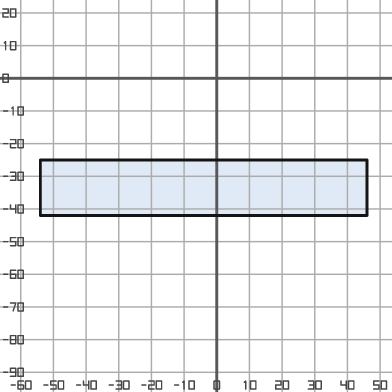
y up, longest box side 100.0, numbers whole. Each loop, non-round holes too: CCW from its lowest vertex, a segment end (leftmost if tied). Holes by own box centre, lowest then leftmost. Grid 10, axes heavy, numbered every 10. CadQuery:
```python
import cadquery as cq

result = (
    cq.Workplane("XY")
    .moveTo(-54.0, -42.0)
    .lineTo(46.0, -42.0)
    .lineTo(46.0, -25.0)
    .lineTo(-54.0, -25.0)
    .close()
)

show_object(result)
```